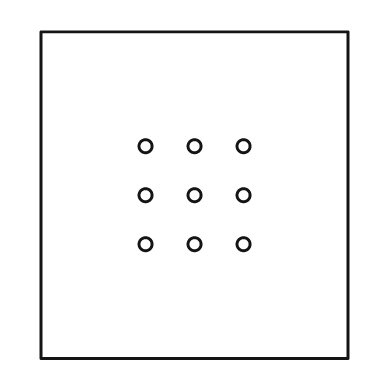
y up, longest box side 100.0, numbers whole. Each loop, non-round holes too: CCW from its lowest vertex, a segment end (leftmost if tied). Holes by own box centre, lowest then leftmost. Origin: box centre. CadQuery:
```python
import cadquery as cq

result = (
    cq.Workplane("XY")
    .moveTo(-47.0, -50.0)
    .lineTo(47.0, -50.0)
    .lineTo(47.0, 50.0)
    .lineTo(-47.0, 50.0)
    .close()
    .moveTo(-15.0, -15.0)
    .circle(2.0)
    .moveTo(0.0, -15.0)
    .circle(2.0)
    .moveTo(15.0, -15.0)
    .circle(2.0)
    .moveTo(-15.0, 0.0)
    .circle(2.0)
    .moveTo(0.0, 0.0)
    .circle(2.0)
    .moveTo(15.0, 0.0)
    .circle(2.0)
    .moveTo(-15.0, 15.0)
    .circle(2.0)
    .moveTo(0.0, 15.0)
    .circle(2.0)
    .moveTo(15.0, 15.0)
    .circle(2.0)
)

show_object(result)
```